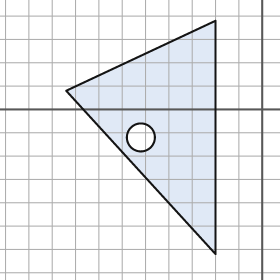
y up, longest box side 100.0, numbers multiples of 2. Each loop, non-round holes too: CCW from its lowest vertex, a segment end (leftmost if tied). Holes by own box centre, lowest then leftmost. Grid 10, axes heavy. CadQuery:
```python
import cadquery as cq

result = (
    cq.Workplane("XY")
    .moveTo(-20.0, -62.0)
    .lineTo(-20.0, 38.0)
    .lineTo(-84.0, 8.0)
    .close()
    .moveTo(-52.0, -12.0)
    .circle(6.0)
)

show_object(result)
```